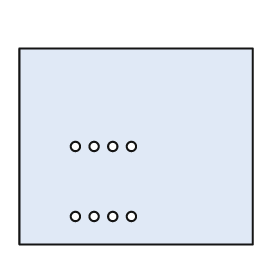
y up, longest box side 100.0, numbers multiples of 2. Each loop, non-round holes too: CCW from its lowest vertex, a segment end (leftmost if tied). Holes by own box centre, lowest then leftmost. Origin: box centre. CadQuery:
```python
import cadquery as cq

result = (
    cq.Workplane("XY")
    .moveTo(-50.0, -42.0)
    .lineTo(50.0, -42.0)
    .lineTo(50.0, 42.0)
    .lineTo(-50.0, 42.0)
    .close()
    .moveTo(-26.0, -30.0)
    .circle(2.0)
    .moveTo(-18.0, -30.0)
    .circle(2.0)
    .moveTo(-10.0, -30.0)
    .circle(2.0)
    .moveTo(-2.0, -30.0)
    .circle(2.0)
    .moveTo(-26.0, 0.0)
    .circle(2.0)
    .moveTo(-18.0, 0.0)
    .circle(2.0)
    .moveTo(-10.0, 0.0)
    .circle(2.0)
    .moveTo(-2.0, 0.0)
    .circle(2.0)
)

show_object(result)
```